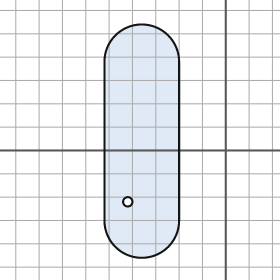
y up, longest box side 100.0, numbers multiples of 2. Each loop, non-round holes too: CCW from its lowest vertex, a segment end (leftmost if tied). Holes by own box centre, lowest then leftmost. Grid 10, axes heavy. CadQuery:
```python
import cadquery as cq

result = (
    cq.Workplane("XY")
    .moveTo(-52.0, -30.0)
    .threePointArc((-36.0, -46.0), (-20.0, -30.0))
    .lineTo(-20.0, 38.0)
    .threePointArc((-36.0, 54.0), (-52.0, 38.0))
    .close()
    .moveTo(-42.0, -22.0)
    .circle(2.0)
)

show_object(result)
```